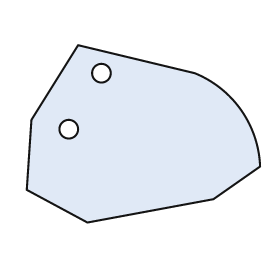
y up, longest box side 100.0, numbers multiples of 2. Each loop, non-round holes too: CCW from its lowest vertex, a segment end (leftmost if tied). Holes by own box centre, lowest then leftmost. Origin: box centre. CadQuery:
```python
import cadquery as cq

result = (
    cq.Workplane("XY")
    .moveTo(-24.0, -38.0)
    .lineTo(30.0, -28.0)
    .lineTo(50.0, -14.0)
    .threePointArc((42.0, 10.0), (22.0, 26.0))
    .lineTo(-28.0, 38.0)
    .lineTo(-48.0, 6.0)
    .lineTo(-50.0, -24.0)
    .close()
    .moveTo(-32.0, 2.0)
    .circle(4.0)
    .moveTo(-18.0, 26.0)
    .circle(4.0)
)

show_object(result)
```